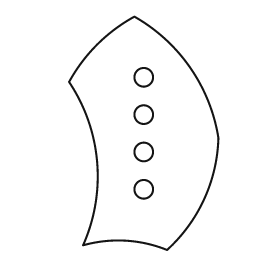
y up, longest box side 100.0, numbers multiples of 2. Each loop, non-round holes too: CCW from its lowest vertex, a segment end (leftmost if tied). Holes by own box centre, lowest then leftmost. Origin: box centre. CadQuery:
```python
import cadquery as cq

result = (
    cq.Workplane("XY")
    .moveTo(10.0, -50.0)
    .threePointArc((26.0, -28.0), (32.0, -2.0))
    .threePointArc((20.0, 28.0), (-4.0, 50.0))
    .threePointArc((-20.0, 38.0), (-32.0, 22.0))
    .threePointArc((-20.0, -12.0), (-26.0, -48.0))
    .threePointArc((-8.0, -46.0), (10.0, -50.0))
    .close()
    .moveTo(0.0, -24.0)
    .circle(4.0)
    .moveTo(0.0, -8.0)
    .circle(4.0)
    .moveTo(0.0, 8.0)
    .circle(4.0)
    .moveTo(0.0, 24.0)
    .circle(4.0)
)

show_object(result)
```